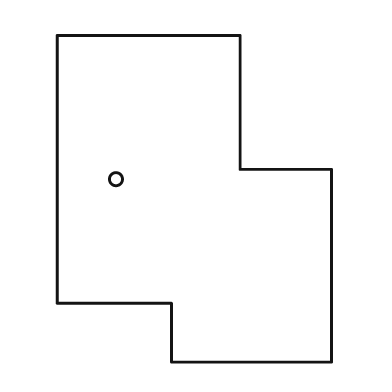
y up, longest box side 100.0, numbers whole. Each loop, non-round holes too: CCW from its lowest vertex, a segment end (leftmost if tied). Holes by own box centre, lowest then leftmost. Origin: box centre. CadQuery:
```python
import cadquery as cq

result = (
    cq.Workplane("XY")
    .moveTo(-7.0, -50.0)
    .lineTo(42.0, -50.0)
    .lineTo(42.0, 9.0)
    .lineTo(14.0, 9.0)
    .lineTo(14.0, 50.0)
    .lineTo(-42.0, 50.0)
    .lineTo(-42.0, -32.0)
    .lineTo(-7.0, -32.0)
    .close()
    .moveTo(-24.0, 6.0)
    .circle(2.0)
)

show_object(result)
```